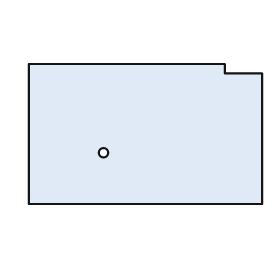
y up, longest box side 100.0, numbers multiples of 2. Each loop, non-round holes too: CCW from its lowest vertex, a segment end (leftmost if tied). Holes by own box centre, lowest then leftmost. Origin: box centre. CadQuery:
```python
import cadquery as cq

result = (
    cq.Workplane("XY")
    .moveTo(-50.0, -30.0)
    .lineTo(50.0, -30.0)
    .lineTo(50.0, 26.0)
    .lineTo(34.0, 26.0)
    .lineTo(34.0, 30.0)
    .lineTo(-50.0, 30.0)
    .close()
    .moveTo(-18.0, -8.0)
    .circle(2.0)
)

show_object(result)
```